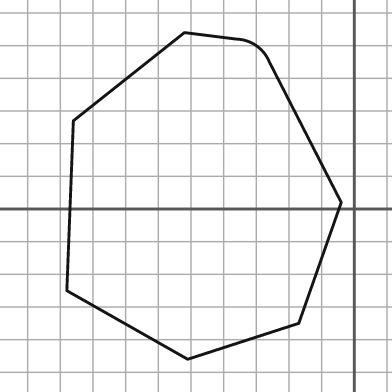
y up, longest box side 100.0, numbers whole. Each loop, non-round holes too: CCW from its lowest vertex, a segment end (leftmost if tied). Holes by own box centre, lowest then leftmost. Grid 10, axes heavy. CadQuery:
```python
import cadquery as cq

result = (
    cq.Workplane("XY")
    .moveTo(-51.0, -46.0)
    .lineTo(-17.0, -35.0)
    .lineTo(-4.0, 2.0)
    .lineTo(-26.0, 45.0)
    .threePointArc((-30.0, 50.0), (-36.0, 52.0))
    .lineTo(-52.0, 54.0)
    .lineTo(-86.0, 27.0)
    .lineTo(-88.0, -25.0)
    .close()
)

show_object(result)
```